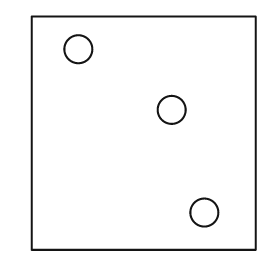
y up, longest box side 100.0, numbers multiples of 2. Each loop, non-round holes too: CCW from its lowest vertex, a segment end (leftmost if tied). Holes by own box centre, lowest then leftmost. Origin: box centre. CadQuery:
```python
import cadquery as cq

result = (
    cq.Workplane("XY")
    .moveTo(-48.0, -50.0)
    .lineTo(48.0, -50.0)
    .lineTo(48.0, 50.0)
    .lineTo(-48.0, 50.0)
    .close()
    .moveTo(26.0, -34.0)
    .circle(6.0)
    .moveTo(12.0, 10.0)
    .circle(6.0)
    .moveTo(-28.0, 36.0)
    .circle(6.0)
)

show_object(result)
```